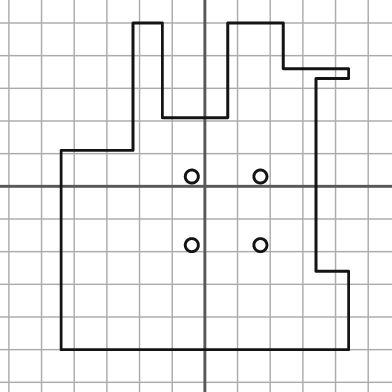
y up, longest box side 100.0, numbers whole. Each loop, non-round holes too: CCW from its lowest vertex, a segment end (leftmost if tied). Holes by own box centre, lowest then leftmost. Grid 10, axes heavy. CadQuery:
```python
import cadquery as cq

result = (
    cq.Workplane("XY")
    .moveTo(-44.0, -50.0)
    .lineTo(44.0, -50.0)
    .lineTo(44.0, -26.0)
    .lineTo(34.0, -26.0)
    .lineTo(34.0, 33.0)
    .lineTo(44.0, 33.0)
    .lineTo(44.0, 36.0)
    .lineTo(24.0, 36.0)
    .lineTo(24.0, 50.0)
    .lineTo(7.0, 50.0)
    .lineTo(7.0, 21.0)
    .lineTo(-13.0, 21.0)
    .lineTo(-13.0, 50.0)
    .lineTo(-22.0, 50.0)
    .lineTo(-22.0, 11.0)
    .lineTo(-44.0, 11.0)
    .close()
    .moveTo(-4.0, -18.0)
    .circle(2.0)
    .moveTo(17.0, -18.0)
    .circle(2.0)
    .moveTo(-4.0, 3.0)
    .circle(2.0)
    .moveTo(17.0, 3.0)
    .circle(2.0)
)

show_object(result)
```